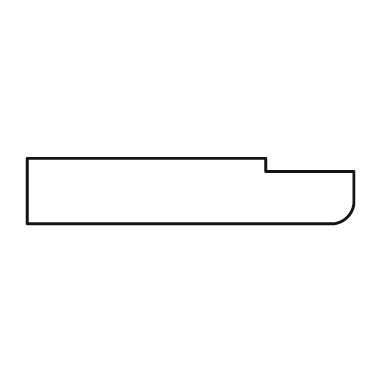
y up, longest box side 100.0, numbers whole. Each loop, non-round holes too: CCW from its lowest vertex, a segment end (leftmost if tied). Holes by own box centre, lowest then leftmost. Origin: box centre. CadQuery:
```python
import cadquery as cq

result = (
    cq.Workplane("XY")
    .moveTo(-50.0, -10.0)
    .lineTo(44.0, -10.0)
    .threePointArc((48.0, -8.0), (50.0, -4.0))
    .lineTo(50.0, 6.0)
    .lineTo(23.0, 6.0)
    .lineTo(23.0, 10.0)
    .lineTo(-50.0, 10.0)
    .close()
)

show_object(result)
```